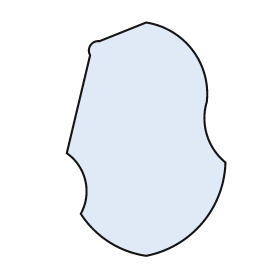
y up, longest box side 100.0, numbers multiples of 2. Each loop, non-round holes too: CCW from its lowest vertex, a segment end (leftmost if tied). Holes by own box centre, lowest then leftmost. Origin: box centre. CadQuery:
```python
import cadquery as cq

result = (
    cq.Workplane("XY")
    .moveTo(0.0, -50.0)
    .threePointArc((24.0, -36.0), (34.0, -10.0))
    .threePointArc((26.0, 2.0), (26.0, 16.0))
    .threePointArc((20.0, 38.0), (0.0, 50.0))
    .lineTo(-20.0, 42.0)
    .threePointArc((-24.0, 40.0), (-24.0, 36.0))
    .lineTo(-34.0, -6.0)
    .threePointArc((-26.0, -18.0), (-28.0, -32.0))
    .threePointArc((-16.0, -44.0), (0.0, -50.0))
    .close()
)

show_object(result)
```